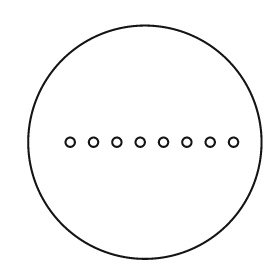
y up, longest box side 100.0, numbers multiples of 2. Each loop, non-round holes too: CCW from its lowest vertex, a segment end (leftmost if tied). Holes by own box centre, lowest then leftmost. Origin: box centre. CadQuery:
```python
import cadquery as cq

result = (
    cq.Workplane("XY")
    .moveTo(0.0, 0.0)
    .circle(50.0)
    .moveTo(-32.0, 0.0)
    .circle(2.0)
    .moveTo(-22.0, 0.0)
    .circle(2.0)
    .moveTo(-12.0, 0.0)
    .circle(2.0)
    .moveTo(-2.0, 0.0)
    .circle(2.0)
    .moveTo(8.0, 0.0)
    .circle(2.0)
    .moveTo(18.0, 0.0)
    .circle(2.0)
    .moveTo(28.0, 0.0)
    .circle(2.0)
    .moveTo(38.0, 0.0)
    .circle(2.0)
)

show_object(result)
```